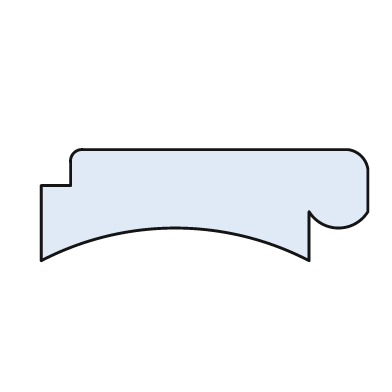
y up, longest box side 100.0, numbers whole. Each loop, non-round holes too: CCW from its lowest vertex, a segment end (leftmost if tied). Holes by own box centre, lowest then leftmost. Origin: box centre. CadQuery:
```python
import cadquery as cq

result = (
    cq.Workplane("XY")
    .moveTo(-50.0, -17.0)
    .threePointArc((-9.0, -7.0), (32.0, -17.0))
    .lineTo(32.0, -2.0)
    .threePointArc((41.0, -7.0), (50.0, -2.0))
    .lineTo(50.0, 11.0)
    .threePointArc((48.0, 15.0), (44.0, 17.0))
    .lineTo(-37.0, 17.0)
    .threePointArc((-40.0, 16.0), (-41.0, 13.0))
    .lineTo(-41.0, 6.0)
    .lineTo(-50.0, 6.0)
    .close()
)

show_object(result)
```